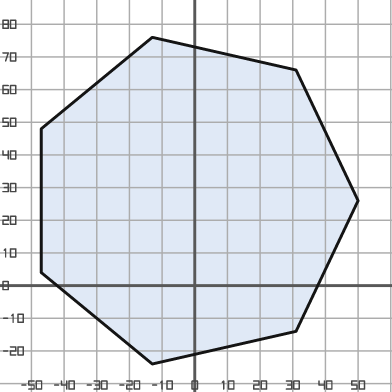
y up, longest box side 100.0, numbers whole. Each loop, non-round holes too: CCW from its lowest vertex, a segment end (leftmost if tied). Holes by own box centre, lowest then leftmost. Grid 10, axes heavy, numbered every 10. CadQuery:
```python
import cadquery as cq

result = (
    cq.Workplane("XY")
    .moveTo(-13.0, -24.0)
    .lineTo(31.0, -14.0)
    .lineTo(50.0, 26.0)
    .lineTo(31.0, 66.0)
    .lineTo(-13.0, 76.0)
    .lineTo(-47.0, 48.0)
    .lineTo(-47.0, 4.0)
    .close()
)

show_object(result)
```